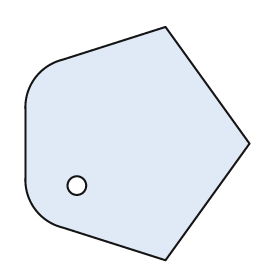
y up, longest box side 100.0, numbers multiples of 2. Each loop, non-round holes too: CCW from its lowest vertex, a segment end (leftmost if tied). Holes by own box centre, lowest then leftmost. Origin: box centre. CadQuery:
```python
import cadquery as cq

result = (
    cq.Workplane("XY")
    .moveTo(12.0, -50.0)
    .lineTo(48.0, 0.0)
    .lineTo(12.0, 50.0)
    .lineTo(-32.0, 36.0)
    .threePointArc((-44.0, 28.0), (-48.0, 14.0))
    .lineTo(-48.0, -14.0)
    .threePointArc((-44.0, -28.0), (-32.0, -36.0))
    .close()
    .moveTo(-26.0, -18.0)
    .circle(4.0)
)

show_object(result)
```